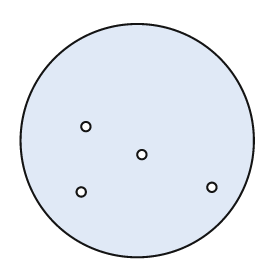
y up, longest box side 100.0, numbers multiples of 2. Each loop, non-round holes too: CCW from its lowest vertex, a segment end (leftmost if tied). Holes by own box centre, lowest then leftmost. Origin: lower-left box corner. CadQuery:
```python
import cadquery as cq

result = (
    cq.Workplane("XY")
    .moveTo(50.0, 50.0)
    .circle(50.0)
    .moveTo(26.0, 28.0)
    .circle(2.0)
    .moveTo(82.0, 30.0)
    .circle(2.0)
    .moveTo(52.0, 44.0)
    .circle(2.0)
    .moveTo(28.0, 56.0)
    .circle(2.0)
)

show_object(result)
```